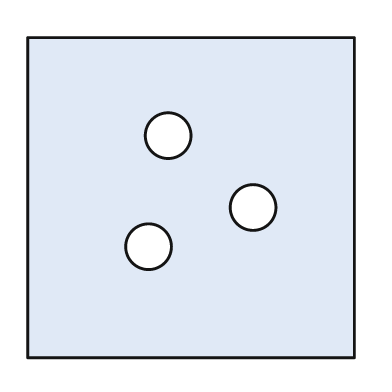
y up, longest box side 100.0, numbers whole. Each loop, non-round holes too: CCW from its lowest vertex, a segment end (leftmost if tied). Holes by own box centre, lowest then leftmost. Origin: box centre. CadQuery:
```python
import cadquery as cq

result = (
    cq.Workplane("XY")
    .moveTo(-50.0, -49.0)
    .lineTo(50.0, -49.0)
    .lineTo(50.0, 49.0)
    .lineTo(-50.0, 49.0)
    .close()
    .moveTo(-13.0, -15.0)
    .circle(7.0)
    .moveTo(19.0, -3.0)
    .circle(7.0)
    .moveTo(-7.0, 19.0)
    .circle(7.0)
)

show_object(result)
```